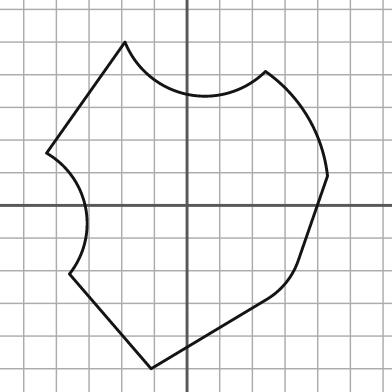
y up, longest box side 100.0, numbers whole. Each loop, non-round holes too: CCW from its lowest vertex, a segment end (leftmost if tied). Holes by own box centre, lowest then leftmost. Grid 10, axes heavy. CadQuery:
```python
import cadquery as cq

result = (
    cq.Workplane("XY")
    .moveTo(-11.0, -50.0)
    .lineTo(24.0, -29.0)
    .threePointArc((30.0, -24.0), (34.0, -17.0))
    .lineTo(43.0, 9.0)
    .threePointArc((37.0, 27.0), (24.0, 41.0))
    .threePointArc((0.0, 34.0), (-19.0, 50.0))
    .lineTo(-43.0, 16.0)
    .threePointArc((-31.0, -1.0), (-36.0, -21.0))
    .close()
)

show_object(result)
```